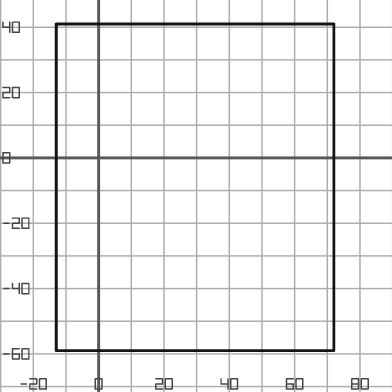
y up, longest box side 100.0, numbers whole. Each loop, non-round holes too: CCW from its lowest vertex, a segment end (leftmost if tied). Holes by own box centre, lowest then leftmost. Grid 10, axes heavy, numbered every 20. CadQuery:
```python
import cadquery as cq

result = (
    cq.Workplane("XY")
    .moveTo(-13.0, -59.0)
    .lineTo(72.0, -59.0)
    .lineTo(72.0, 41.0)
    .lineTo(-13.0, 41.0)
    .close()
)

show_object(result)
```